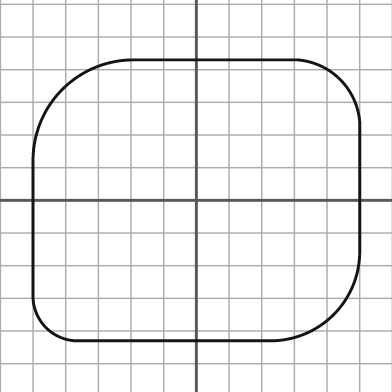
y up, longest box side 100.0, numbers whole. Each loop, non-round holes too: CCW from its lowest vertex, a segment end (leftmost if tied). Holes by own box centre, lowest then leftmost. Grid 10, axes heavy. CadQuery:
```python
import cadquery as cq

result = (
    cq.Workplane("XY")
    .moveTo(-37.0, -43.0)
    .lineTo(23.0, -43.0)
    .threePointArc((42.0, -35.0), (50.0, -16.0))
    .lineTo(50.0, 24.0)
    .threePointArc((44.0, 37.0), (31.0, 43.0))
    .lineTo(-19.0, 43.0)
    .threePointArc((-41.0, 34.0), (-50.0, 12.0))
    .lineTo(-50.0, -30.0)
    .threePointArc((-46.0, -39.0), (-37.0, -43.0))
    .close()
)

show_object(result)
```